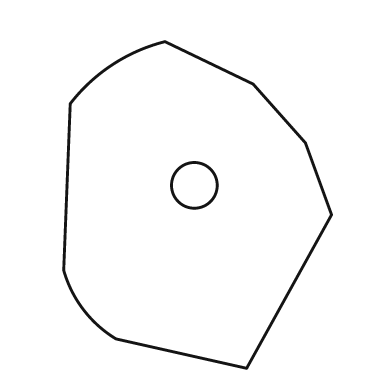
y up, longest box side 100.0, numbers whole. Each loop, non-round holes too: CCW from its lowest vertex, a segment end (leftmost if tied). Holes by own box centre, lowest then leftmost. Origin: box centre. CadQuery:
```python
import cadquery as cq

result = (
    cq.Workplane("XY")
    .moveTo(15.0, -50.0)
    .lineTo(41.0, -3.0)
    .lineTo(33.0, 19.0)
    .lineTo(17.0, 37.0)
    .lineTo(-10.0, 50.0)
    .threePointArc((-26.0, 43.0), (-39.0, 31.0))
    .lineTo(-41.0, -20.0)
    .threePointArc((-35.0, -32.0), (-25.0, -41.0))
    .close()
    .moveTo(-1.0, 6.0)
    .circle(7.0)
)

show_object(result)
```